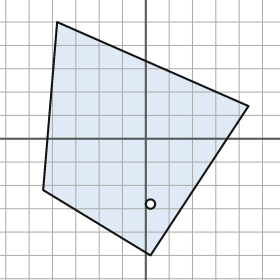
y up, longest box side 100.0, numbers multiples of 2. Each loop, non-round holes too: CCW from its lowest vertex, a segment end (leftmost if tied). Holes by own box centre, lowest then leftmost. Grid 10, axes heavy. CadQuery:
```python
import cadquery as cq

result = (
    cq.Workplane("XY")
    .moveTo(2.0, -50.0)
    .lineTo(44.0, 14.0)
    .lineTo(-38.0, 50.0)
    .lineTo(-44.0, -22.0)
    .close()
    .moveTo(2.0, -28.0)
    .circle(2.0)
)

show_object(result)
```